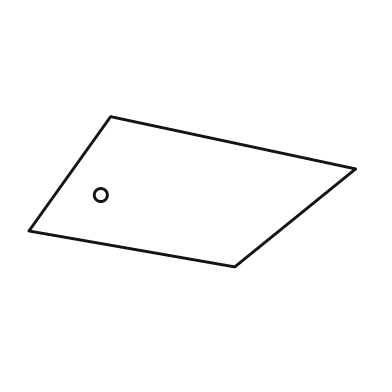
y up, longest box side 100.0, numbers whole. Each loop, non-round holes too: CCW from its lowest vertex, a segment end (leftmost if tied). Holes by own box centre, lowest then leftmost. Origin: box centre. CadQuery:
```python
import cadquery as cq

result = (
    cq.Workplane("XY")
    .moveTo(13.0, -23.0)
    .lineTo(50.0, 7.0)
    .lineTo(-25.0, 23.0)
    .lineTo(-50.0, -12.0)
    .close()
    .moveTo(-28.0, -1.0)
    .circle(2.0)
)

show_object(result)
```